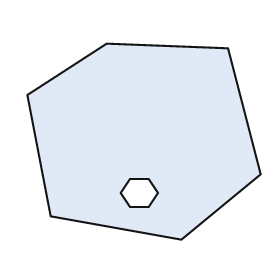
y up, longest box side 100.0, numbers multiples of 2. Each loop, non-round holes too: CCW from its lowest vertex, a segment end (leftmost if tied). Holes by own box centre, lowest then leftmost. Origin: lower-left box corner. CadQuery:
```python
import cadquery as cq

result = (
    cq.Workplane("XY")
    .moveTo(66.0, 0.0)
    .lineTo(100.0, 28.0)
    .lineTo(86.0, 82.0)
    .lineTo(34.0, 84.0)
    .lineTo(0.0, 62.0)
    .lineTo(10.0, 10.0)
    .close()
    .moveTo(44.0, 14.0)
    .lineTo(52.0, 14.0)
    .lineTo(56.0, 20.0)
    .lineTo(52.0, 26.0)
    .lineTo(44.0, 26.0)
    .lineTo(40.0, 20.0)
    .close()
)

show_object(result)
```